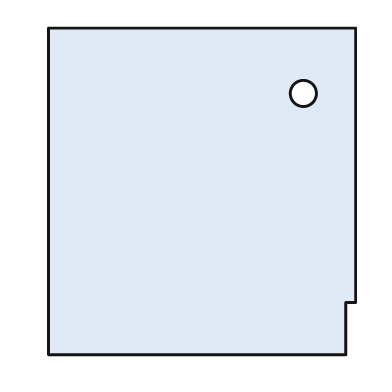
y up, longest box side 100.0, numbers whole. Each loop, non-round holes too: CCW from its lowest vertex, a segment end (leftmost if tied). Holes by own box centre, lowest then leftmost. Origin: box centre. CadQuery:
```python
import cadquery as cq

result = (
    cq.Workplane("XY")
    .moveTo(-47.0, -50.0)
    .lineTo(44.0, -50.0)
    .lineTo(44.0, -34.0)
    .lineTo(47.0, -34.0)
    .lineTo(47.0, 50.0)
    .lineTo(-47.0, 50.0)
    .close()
    .moveTo(31.0, 30.0)
    .circle(4.0)
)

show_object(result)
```